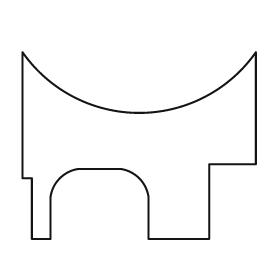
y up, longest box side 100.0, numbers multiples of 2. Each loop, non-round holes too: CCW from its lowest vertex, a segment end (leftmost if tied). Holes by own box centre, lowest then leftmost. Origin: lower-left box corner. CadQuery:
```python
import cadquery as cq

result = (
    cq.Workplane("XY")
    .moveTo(4.0, 0.0)
    .lineTo(12.0, 0.0)
    .lineTo(12.0, 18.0)
    .threePointArc((16.0, 26.0), (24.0, 30.0))
    .lineTo(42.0, 30.0)
    .threePointArc((50.0, 26.0), (54.0, 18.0))
    .lineTo(54.0, 0.0)
    .lineTo(80.0, 0.0)
    .lineTo(80.0, 32.0)
    .lineTo(100.0, 32.0)
    .lineTo(100.0, 80.0)
    .threePointArc((50.0, 54.0), (0.0, 80.0))
    .lineTo(0.0, 26.0)
    .lineTo(4.0, 26.0)
    .close()
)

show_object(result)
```